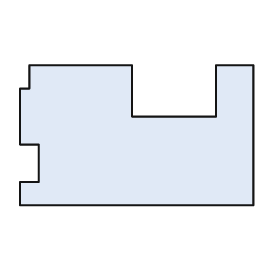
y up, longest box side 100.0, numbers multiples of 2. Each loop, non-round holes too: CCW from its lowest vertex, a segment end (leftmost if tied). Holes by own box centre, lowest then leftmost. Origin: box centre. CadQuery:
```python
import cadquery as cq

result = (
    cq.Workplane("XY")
    .moveTo(-50.0, -30.0)
    .lineTo(50.0, -30.0)
    .lineTo(50.0, 30.0)
    .lineTo(34.0, 30.0)
    .lineTo(34.0, 8.0)
    .lineTo(-2.0, 8.0)
    .lineTo(-2.0, 30.0)
    .lineTo(-46.0, 30.0)
    .lineTo(-46.0, 20.0)
    .lineTo(-50.0, 20.0)
    .lineTo(-50.0, -4.0)
    .lineTo(-42.0, -4.0)
    .lineTo(-42.0, -20.0)
    .lineTo(-50.0, -20.0)
    .close()
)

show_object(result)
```